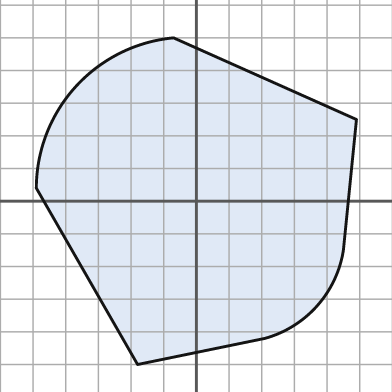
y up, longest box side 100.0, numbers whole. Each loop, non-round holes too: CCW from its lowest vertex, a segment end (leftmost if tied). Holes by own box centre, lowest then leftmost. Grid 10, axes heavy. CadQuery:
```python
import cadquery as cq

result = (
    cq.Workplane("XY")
    .moveTo(-18.0, -50.0)
    .lineTo(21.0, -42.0)
    .threePointArc((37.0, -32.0), (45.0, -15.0))
    .lineTo(49.0, 25.0)
    .lineTo(-7.0, 50.0)
    .threePointArc((-37.0, 35.0), (-49.0, 4.0))
    .close()
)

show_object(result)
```